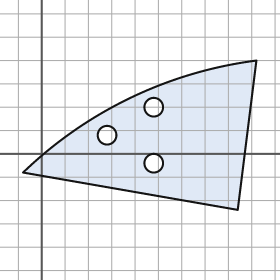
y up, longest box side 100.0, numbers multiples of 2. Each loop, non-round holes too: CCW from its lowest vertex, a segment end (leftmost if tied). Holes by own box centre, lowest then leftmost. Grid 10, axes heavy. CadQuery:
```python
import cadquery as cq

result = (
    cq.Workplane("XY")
    .moveTo(84.0, -24.0)
    .lineTo(92.0, 40.0)
    .threePointArc((38.0, 24.0), (-8.0, -8.0))
    .close()
    .moveTo(48.0, -4.0)
    .circle(4.0)
    .moveTo(28.0, 8.0)
    .circle(4.0)
    .moveTo(48.0, 20.0)
    .circle(4.0)
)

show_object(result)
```